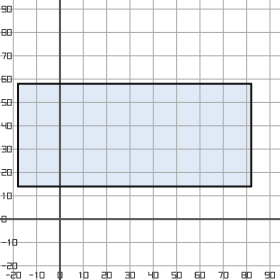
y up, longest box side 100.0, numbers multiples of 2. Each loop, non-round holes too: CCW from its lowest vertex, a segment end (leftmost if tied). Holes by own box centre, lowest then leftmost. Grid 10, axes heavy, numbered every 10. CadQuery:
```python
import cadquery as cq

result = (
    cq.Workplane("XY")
    .moveTo(-18.0, 14.0)
    .lineTo(82.0, 14.0)
    .lineTo(82.0, 58.0)
    .lineTo(-18.0, 58.0)
    .close()
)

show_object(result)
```